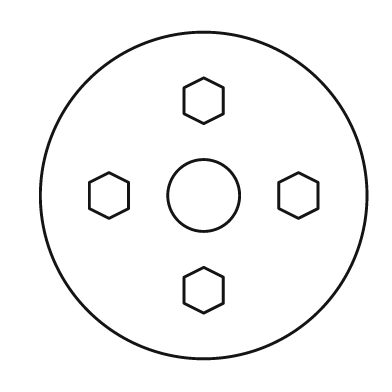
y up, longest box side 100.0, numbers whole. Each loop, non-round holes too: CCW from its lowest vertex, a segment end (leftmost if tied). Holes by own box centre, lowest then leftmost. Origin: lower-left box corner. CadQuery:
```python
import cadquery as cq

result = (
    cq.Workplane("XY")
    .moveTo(50.0, 50.0)
    .circle(50.0)
    .moveTo(50.0, 14.0)
    .lineTo(56.0, 17.0)
    .lineTo(56.0, 25.0)
    .lineTo(50.0, 28.0)
    .lineTo(44.0, 25.0)
    .lineTo(44.0, 17.0)
    .close()
    .moveTo(21.0, 43.0)
    .lineTo(27.0, 46.0)
    .lineTo(27.0, 54.0)
    .lineTo(21.0, 57.0)
    .lineTo(15.0, 54.0)
    .lineTo(15.0, 46.0)
    .close()
    .moveTo(50.0, 50.0)
    .circle(11.0)
    .moveTo(79.0, 43.0)
    .lineTo(85.0, 46.0)
    .lineTo(85.0, 54.0)
    .lineTo(79.0, 57.0)
    .lineTo(73.0, 54.0)
    .lineTo(73.0, 46.0)
    .close()
    .moveTo(50.0, 72.0)
    .lineTo(56.0, 75.0)
    .lineTo(56.0, 83.0)
    .lineTo(50.0, 86.0)
    .lineTo(44.0, 83.0)
    .lineTo(44.0, 75.0)
    .close()
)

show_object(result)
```